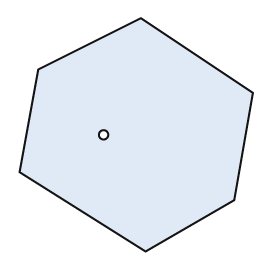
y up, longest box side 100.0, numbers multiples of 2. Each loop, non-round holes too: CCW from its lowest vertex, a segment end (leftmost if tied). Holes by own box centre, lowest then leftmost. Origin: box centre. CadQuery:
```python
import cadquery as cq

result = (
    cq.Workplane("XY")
    .moveTo(4.0, -50.0)
    .lineTo(42.0, -28.0)
    .lineTo(50.0, 18.0)
    .lineTo(2.0, 50.0)
    .lineTo(-42.0, 28.0)
    .lineTo(-50.0, -16.0)
    .close()
    .moveTo(-14.0, 0.0)
    .circle(2.0)
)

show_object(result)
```